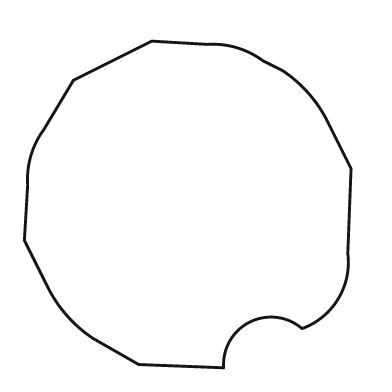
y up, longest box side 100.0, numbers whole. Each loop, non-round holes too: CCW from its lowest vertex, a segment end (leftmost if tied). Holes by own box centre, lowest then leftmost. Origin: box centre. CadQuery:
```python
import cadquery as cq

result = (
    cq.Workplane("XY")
    .moveTo(11.0, -50.0)
    .threePointArc((19.0, -36.0), (35.0, -38.0))
    .threePointArc((46.0, -29.0), (49.0, -15.0))
    .lineTo(50.0, 11.0)
    .lineTo(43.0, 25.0)
    .threePointArc((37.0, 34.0), (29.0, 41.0))
    .lineTo(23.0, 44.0)
    .threePointArc((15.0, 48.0), (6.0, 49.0))
    .lineTo(-11.0, 50.0)
    .lineTo(-35.0, 38.0)
    .lineTo(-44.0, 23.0)
    .threePointArc((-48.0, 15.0), (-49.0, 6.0))
    .lineTo(-50.0, -11.0)
    .lineTo(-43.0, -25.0)
    .threePointArc((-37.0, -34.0), (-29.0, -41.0))
    .lineTo(-15.0, -49.0)
    .close()
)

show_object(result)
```